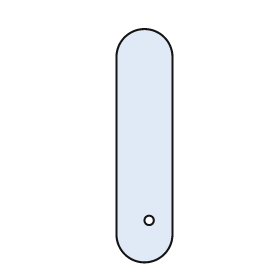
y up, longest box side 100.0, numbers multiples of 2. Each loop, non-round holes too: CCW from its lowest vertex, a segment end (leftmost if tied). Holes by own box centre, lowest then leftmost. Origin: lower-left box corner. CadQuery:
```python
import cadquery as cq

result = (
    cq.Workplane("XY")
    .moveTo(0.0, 12.0)
    .threePointArc((12.0, 0.0), (24.0, 12.0))
    .lineTo(24.0, 88.0)
    .threePointArc((12.0, 100.0), (0.0, 88.0))
    .close()
    .moveTo(14.0, 18.0)
    .circle(2.0)
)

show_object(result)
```